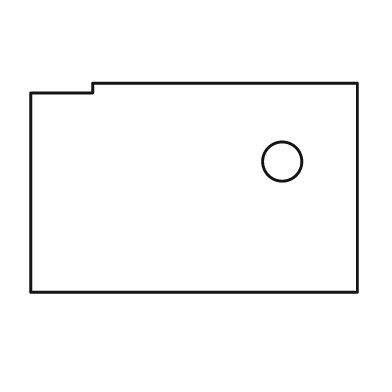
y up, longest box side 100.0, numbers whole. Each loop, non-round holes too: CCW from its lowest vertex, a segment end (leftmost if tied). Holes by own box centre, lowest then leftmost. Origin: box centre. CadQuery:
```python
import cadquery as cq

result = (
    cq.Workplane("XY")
    .moveTo(-50.0, -32.0)
    .lineTo(50.0, -32.0)
    .lineTo(50.0, 32.0)
    .lineTo(-31.0, 32.0)
    .lineTo(-31.0, 29.0)
    .lineTo(-50.0, 29.0)
    .close()
    .moveTo(27.0, 8.0)
    .circle(6.0)
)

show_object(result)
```